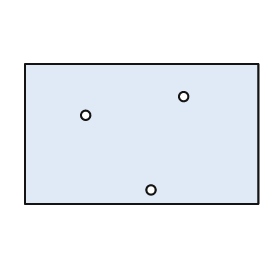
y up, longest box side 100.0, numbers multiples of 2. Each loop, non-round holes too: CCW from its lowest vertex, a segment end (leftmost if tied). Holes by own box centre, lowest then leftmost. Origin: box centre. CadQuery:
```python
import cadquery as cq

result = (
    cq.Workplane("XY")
    .moveTo(-50.0, -30.0)
    .lineTo(50.0, -30.0)
    .lineTo(50.0, 30.0)
    .lineTo(-50.0, 30.0)
    .close()
    .moveTo(4.0, -24.0)
    .circle(2.0)
    .moveTo(-24.0, 8.0)
    .circle(2.0)
    .moveTo(18.0, 16.0)
    .circle(2.0)
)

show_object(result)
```